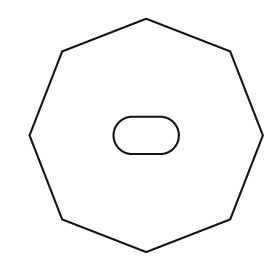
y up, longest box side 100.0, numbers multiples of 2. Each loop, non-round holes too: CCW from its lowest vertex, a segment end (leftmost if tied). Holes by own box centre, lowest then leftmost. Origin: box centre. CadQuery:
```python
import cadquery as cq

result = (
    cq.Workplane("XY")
    .moveTo(0.0, -50.0)
    .lineTo(36.0, -36.0)
    .lineTo(50.0, 0.0)
    .lineTo(36.0, 36.0)
    .lineTo(0.0, 50.0)
    .lineTo(-36.0, 36.0)
    .lineTo(-50.0, 0.0)
    .lineTo(-36.0, -36.0)
    .close()
    .moveTo(-6.0, -8.0)
    .lineTo(6.0, -8.0)
    .threePointArc((14.0, 0.0), (6.0, 8.0))
    .lineTo(-6.0, 8.0)
    .threePointArc((-14.0, 0.0), (-6.0, -8.0))
    .close()
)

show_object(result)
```